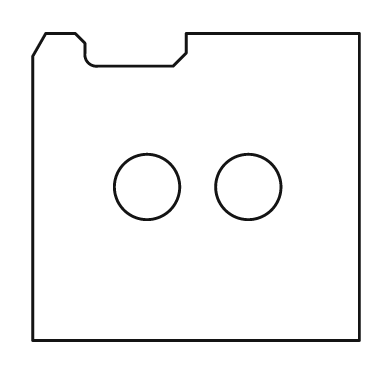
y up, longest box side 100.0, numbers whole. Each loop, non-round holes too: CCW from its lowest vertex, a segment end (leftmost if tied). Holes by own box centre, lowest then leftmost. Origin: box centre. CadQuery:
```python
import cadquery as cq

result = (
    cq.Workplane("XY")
    .moveTo(-50.0, -47.0)
    .lineTo(50.0, -47.0)
    .lineTo(50.0, 47.0)
    .lineTo(-3.0, 47.0)
    .lineTo(-3.0, 41.0)
    .lineTo(-7.0, 37.0)
    .lineTo(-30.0, 37.0)
    .threePointArc((-33.0, 38.0), (-34.0, 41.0))
    .lineTo(-34.0, 44.0)
    .lineTo(-37.0, 47.0)
    .lineTo(-46.0, 47.0)
    .lineTo(-50.0, 40.0)
    .close()
    .moveTo(-15.0, 0.0)
    .circle(10.0)
    .moveTo(16.0, 0.0)
    .circle(10.0)
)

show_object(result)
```